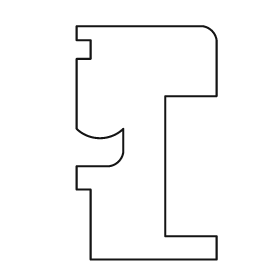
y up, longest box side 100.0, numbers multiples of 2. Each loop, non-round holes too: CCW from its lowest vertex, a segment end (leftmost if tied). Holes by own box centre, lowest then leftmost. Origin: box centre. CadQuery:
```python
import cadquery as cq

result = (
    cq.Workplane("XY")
    .moveTo(-24.0, -50.0)
    .lineTo(30.0, -50.0)
    .lineTo(30.0, -40.0)
    .lineTo(8.0, -40.0)
    .lineTo(8.0, 20.0)
    .lineTo(30.0, 20.0)
    .lineTo(30.0, 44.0)
    .threePointArc((28.0, 48.0), (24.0, 50.0))
    .lineTo(-30.0, 50.0)
    .lineTo(-30.0, 44.0)
    .lineTo(-24.0, 44.0)
    .lineTo(-24.0, 36.0)
    .lineTo(-30.0, 36.0)
    .lineTo(-30.0, 6.0)
    .threePointArc((-20.0, 2.0), (-10.0, 6.0))
    .lineTo(-10.0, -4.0)
    .threePointArc((-12.0, -8.0), (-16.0, -10.0))
    .lineTo(-30.0, -10.0)
    .lineTo(-30.0, -20.0)
    .lineTo(-24.0, -20.0)
    .close()
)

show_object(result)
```